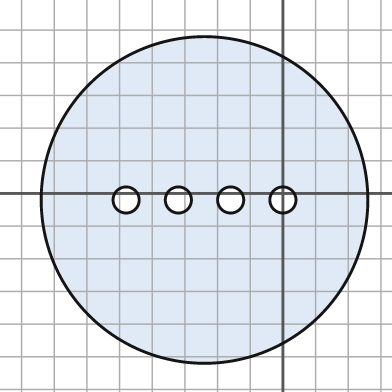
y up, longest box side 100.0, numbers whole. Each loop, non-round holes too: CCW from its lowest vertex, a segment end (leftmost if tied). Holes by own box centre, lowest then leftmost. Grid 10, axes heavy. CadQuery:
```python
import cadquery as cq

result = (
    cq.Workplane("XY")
    .moveTo(-24.0, -2.0)
    .circle(50.0)
    .moveTo(-48.0, -2.0)
    .circle(4.0)
    .moveTo(-32.0, -2.0)
    .circle(4.0)
    .moveTo(-16.0, -2.0)
    .circle(4.0)
    .moveTo(0.0, -2.0)
    .circle(4.0)
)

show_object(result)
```